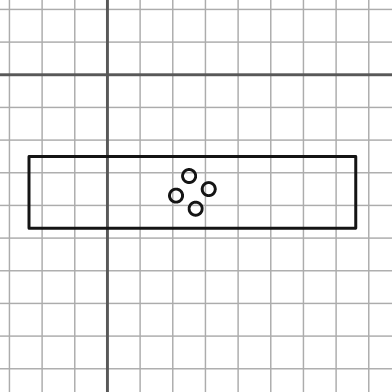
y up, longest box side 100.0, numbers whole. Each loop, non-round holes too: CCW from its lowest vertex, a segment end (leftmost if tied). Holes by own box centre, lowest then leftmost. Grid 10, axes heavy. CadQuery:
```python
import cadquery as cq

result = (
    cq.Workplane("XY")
    .moveTo(-24.0, -47.0)
    .lineTo(76.0, -47.0)
    .lineTo(76.0, -25.0)
    .lineTo(-24.0, -25.0)
    .close()
    .moveTo(27.0, -41.0)
    .circle(2.0)
    .moveTo(21.0, -37.0)
    .circle(2.0)
    .moveTo(31.0, -35.0)
    .circle(2.0)
    .moveTo(25.0, -31.0)
    .circle(2.0)
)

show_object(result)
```